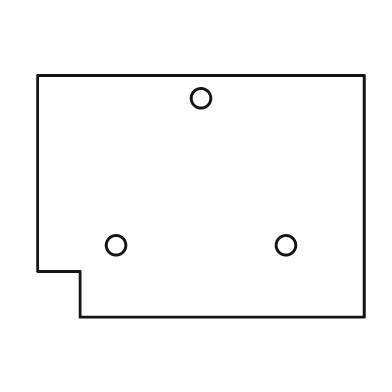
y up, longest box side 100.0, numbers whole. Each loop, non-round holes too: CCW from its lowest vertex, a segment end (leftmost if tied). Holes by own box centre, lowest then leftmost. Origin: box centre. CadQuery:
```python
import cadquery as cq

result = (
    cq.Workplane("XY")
    .moveTo(-37.0, -37.0)
    .lineTo(50.0, -37.0)
    .lineTo(50.0, 37.0)
    .lineTo(-50.0, 37.0)
    .lineTo(-50.0, -23.0)
    .lineTo(-37.0, -23.0)
    .close()
    .moveTo(-26.0, -15.0)
    .circle(3.0)
    .moveTo(26.0, -15.0)
    .circle(3.0)
    .moveTo(0.0, 30.0)
    .circle(3.0)
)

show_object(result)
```